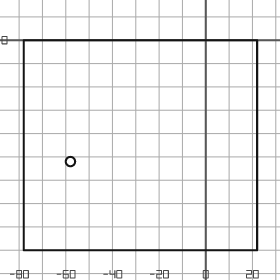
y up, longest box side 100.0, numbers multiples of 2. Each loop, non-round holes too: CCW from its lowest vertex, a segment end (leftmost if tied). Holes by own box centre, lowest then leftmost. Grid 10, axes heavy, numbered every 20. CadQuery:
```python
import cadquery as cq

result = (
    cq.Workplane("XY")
    .moveTo(-78.0, -90.0)
    .lineTo(22.0, -90.0)
    .lineTo(22.0, 0.0)
    .lineTo(-78.0, 0.0)
    .close()
    .moveTo(-58.0, -52.0)
    .circle(2.0)
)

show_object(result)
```